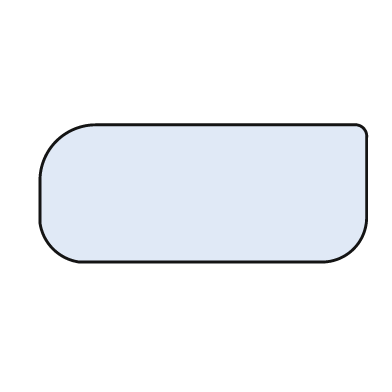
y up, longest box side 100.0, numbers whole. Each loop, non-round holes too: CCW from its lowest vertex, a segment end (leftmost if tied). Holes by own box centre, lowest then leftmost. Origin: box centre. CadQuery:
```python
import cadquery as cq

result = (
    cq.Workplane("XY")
    .moveTo(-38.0, -21.0)
    .lineTo(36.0, -21.0)
    .threePointArc((46.0, -17.0), (50.0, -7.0))
    .lineTo(50.0, 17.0)
    .threePointArc((49.0, 20.0), (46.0, 21.0))
    .lineTo(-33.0, 21.0)
    .threePointArc((-45.0, 16.0), (-50.0, 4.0))
    .lineTo(-50.0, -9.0)
    .threePointArc((-46.0, -17.0), (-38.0, -21.0))
    .close()
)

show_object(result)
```